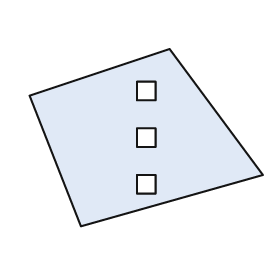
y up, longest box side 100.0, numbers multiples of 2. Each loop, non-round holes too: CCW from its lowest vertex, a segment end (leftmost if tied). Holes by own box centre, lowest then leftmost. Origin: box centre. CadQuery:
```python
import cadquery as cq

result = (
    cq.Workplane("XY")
    .moveTo(-28.0, -38.0)
    .lineTo(50.0, -16.0)
    .lineTo(10.0, 38.0)
    .lineTo(-50.0, 18.0)
    .close()
    .moveTo(-4.0, -24.0)
    .lineTo(4.0, -24.0)
    .lineTo(4.0, -16.0)
    .lineTo(-4.0, -16.0)
    .close()
    .moveTo(-4.0, -4.0)
    .lineTo(4.0, -4.0)
    .lineTo(4.0, 4.0)
    .lineTo(-4.0, 4.0)
    .close()
    .moveTo(-4.0, 16.0)
    .lineTo(4.0, 16.0)
    .lineTo(4.0, 24.0)
    .lineTo(-4.0, 24.0)
    .close()
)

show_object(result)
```